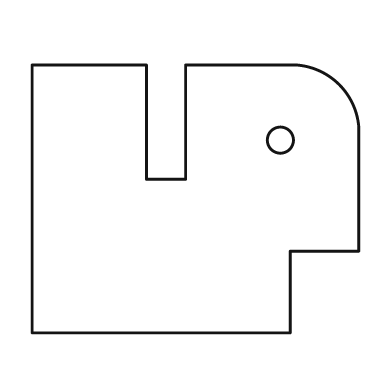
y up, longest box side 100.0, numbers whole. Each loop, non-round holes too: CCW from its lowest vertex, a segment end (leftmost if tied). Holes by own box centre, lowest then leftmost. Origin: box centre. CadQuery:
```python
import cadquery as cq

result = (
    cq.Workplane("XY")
    .moveTo(-50.0, -41.0)
    .lineTo(29.0, -41.0)
    .lineTo(29.0, -16.0)
    .lineTo(50.0, -16.0)
    .lineTo(50.0, 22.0)
    .threePointArc((44.0, 35.0), (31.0, 41.0))
    .lineTo(-3.0, 41.0)
    .lineTo(-3.0, 6.0)
    .lineTo(-15.0, 6.0)
    .lineTo(-15.0, 41.0)
    .lineTo(-50.0, 41.0)
    .close()
    .moveTo(26.0, 18.0)
    .circle(4.0)
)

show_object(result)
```